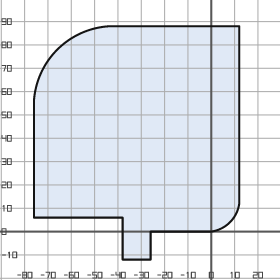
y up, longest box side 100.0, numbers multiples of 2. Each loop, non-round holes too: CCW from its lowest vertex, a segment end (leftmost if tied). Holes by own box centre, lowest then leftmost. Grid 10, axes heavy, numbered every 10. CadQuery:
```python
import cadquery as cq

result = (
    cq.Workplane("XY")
    .moveTo(-38.0, -12.0)
    .lineTo(-26.0, -12.0)
    .lineTo(-26.0, 0.0)
    .lineTo(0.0, 0.0)
    .threePointArc((8.0, 4.0), (12.0, 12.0))
    .lineTo(12.0, 88.0)
    .lineTo(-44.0, 88.0)
    .threePointArc((-66.0, 78.0), (-76.0, 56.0))
    .lineTo(-76.0, 6.0)
    .lineTo(-38.0, 6.0)
    .close()
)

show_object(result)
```